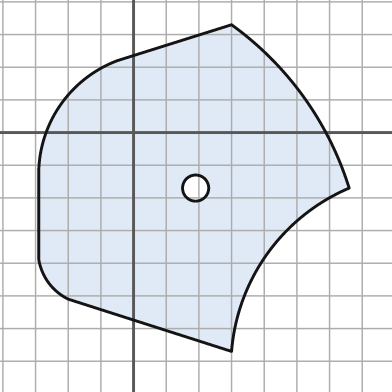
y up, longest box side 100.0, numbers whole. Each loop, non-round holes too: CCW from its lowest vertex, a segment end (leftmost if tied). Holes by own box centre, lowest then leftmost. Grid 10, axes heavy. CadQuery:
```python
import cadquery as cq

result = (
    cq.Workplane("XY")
    .moveTo(30.0, -67.0)
    .threePointArc((41.0, -37.0), (66.0, -17.0))
    .threePointArc((52.0, 11.0), (30.0, 33.0))
    .lineTo(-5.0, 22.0)
    .threePointArc((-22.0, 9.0), (-29.0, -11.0))
    .lineTo(-29.0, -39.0)
    .threePointArc((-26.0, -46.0), (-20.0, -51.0))
    .close()
    .moveTo(19.0, -17.0)
    .circle(4.0)
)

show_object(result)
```